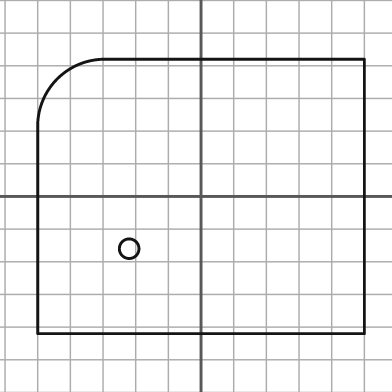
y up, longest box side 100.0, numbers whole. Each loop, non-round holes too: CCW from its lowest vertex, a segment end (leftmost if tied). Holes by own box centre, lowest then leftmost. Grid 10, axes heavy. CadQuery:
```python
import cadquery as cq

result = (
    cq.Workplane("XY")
    .moveTo(-50.0, -42.0)
    .lineTo(50.0, -42.0)
    .lineTo(50.0, 42.0)
    .lineTo(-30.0, 42.0)
    .threePointArc((-44.0, 36.0), (-50.0, 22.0))
    .close()
    .moveTo(-22.0, -16.0)
    .circle(3.0)
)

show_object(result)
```